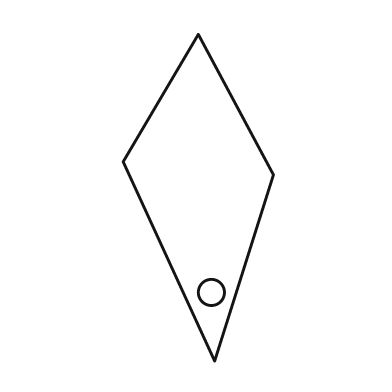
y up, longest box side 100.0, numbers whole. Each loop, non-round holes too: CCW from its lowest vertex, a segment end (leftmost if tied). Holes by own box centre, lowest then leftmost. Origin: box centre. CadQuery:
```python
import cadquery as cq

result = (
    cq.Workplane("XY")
    .moveTo(5.0, -50.0)
    .lineTo(23.0, 7.0)
    .lineTo(0.0, 50.0)
    .lineTo(-23.0, 11.0)
    .close()
    .moveTo(4.0, -29.0)
    .circle(4.0)
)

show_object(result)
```